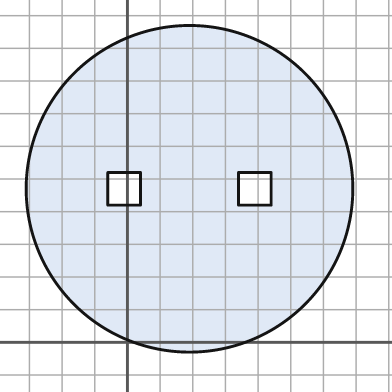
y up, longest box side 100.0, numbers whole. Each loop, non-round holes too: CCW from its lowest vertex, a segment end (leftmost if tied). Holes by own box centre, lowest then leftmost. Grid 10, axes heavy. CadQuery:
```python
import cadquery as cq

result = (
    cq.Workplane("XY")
    .moveTo(19.0, 47.0)
    .circle(50.0)
    .moveTo(-6.0, 42.0)
    .lineTo(4.0, 42.0)
    .lineTo(4.0, 52.0)
    .lineTo(-6.0, 52.0)
    .close()
    .moveTo(34.0, 42.0)
    .lineTo(44.0, 42.0)
    .lineTo(44.0, 52.0)
    .lineTo(34.0, 52.0)
    .close()
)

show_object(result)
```